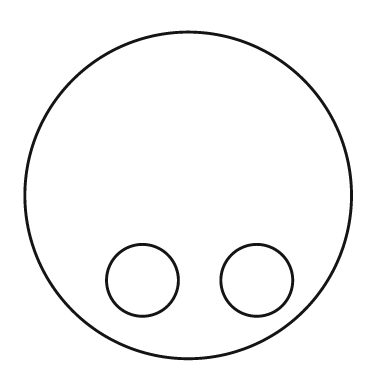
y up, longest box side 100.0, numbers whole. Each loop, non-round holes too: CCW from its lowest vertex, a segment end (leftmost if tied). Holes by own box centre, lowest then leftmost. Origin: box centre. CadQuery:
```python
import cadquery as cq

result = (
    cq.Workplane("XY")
    .moveTo(0.0, 0.0)
    .circle(50.0)
    .moveTo(-14.0, -26.0)
    .circle(11.0)
    .moveTo(21.0, -26.0)
    .circle(11.0)
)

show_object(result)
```